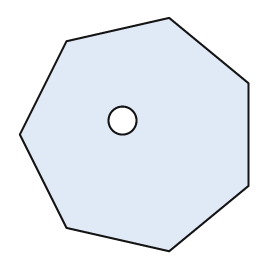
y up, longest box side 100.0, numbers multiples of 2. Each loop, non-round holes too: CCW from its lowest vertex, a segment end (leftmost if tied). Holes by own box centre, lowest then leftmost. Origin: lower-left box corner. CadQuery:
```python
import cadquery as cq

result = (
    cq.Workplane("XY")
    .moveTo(64.0, 0.0)
    .lineTo(98.0, 28.0)
    .lineTo(98.0, 72.0)
    .lineTo(64.0, 100.0)
    .lineTo(20.0, 90.0)
    .lineTo(0.0, 50.0)
    .lineTo(20.0, 10.0)
    .close()
    .moveTo(44.0, 56.0)
    .circle(6.0)
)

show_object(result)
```